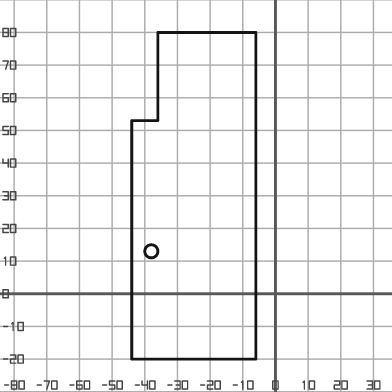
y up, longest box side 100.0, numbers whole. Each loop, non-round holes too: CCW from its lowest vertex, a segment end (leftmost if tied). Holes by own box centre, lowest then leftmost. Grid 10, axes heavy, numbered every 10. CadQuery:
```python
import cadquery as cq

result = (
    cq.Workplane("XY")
    .moveTo(-44.0, -20.0)
    .lineTo(-6.0, -20.0)
    .lineTo(-6.0, 80.0)
    .lineTo(-36.0, 80.0)
    .lineTo(-36.0, 53.0)
    .lineTo(-44.0, 53.0)
    .close()
    .moveTo(-38.0, 13.0)
    .circle(2.0)
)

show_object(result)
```